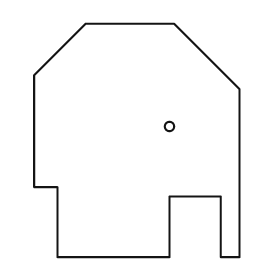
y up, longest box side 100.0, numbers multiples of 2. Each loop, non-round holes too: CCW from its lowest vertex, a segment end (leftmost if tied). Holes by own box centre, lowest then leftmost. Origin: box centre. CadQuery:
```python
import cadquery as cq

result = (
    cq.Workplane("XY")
    .moveTo(-34.0, -50.0)
    .lineTo(14.0, -50.0)
    .lineTo(14.0, -24.0)
    .lineTo(36.0, -24.0)
    .lineTo(36.0, -50.0)
    .lineTo(44.0, -50.0)
    .lineTo(44.0, 22.0)
    .lineTo(16.0, 50.0)
    .lineTo(-22.0, 50.0)
    .lineTo(-44.0, 28.0)
    .lineTo(-44.0, -20.0)
    .lineTo(-34.0, -20.0)
    .close()
    .moveTo(14.0, 6.0)
    .circle(2.0)
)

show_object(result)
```